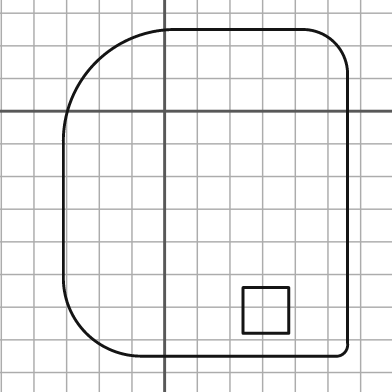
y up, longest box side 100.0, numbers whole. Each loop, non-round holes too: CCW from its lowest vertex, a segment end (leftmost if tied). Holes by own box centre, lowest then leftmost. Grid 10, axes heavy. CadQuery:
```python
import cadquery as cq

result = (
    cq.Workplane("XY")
    .moveTo(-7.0, -75.0)
    .lineTo(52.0, -75.0)
    .threePointArc((55.0, -74.0), (56.0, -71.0))
    .lineTo(56.0, 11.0)
    .threePointArc((52.0, 21.0), (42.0, 25.0))
    .lineTo(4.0, 25.0)
    .threePointArc((-21.0, 15.0), (-31.0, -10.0))
    .lineTo(-31.0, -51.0)
    .threePointArc((-24.0, -68.0), (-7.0, -75.0))
    .close()
    .moveTo(24.0, -68.0)
    .lineTo(38.0, -68.0)
    .lineTo(38.0, -54.0)
    .lineTo(24.0, -54.0)
    .close()
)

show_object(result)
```